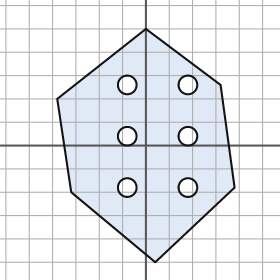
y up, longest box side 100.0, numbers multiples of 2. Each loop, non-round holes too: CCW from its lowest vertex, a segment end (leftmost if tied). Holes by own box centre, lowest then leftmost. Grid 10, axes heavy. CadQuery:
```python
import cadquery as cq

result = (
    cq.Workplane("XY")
    .moveTo(4.0, -50.0)
    .lineTo(38.0, -18.0)
    .lineTo(32.0, 26.0)
    .lineTo(0.0, 50.0)
    .lineTo(-38.0, 20.0)
    .lineTo(-32.0, -20.0)
    .close()
    .moveTo(-8.0, -18.0)
    .circle(4.0)
    .moveTo(18.0, -18.0)
    .circle(4.0)
    .moveTo(-8.0, 4.0)
    .circle(4.0)
    .moveTo(18.0, 4.0)
    .circle(4.0)
    .moveTo(-8.0, 26.0)
    .circle(4.0)
    .moveTo(18.0, 26.0)
    .circle(4.0)
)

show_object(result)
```